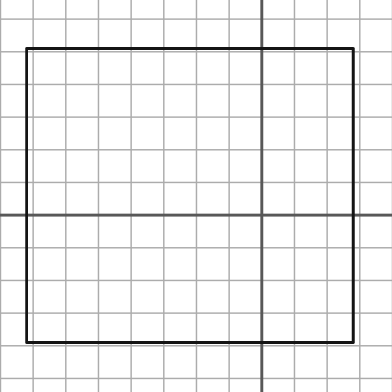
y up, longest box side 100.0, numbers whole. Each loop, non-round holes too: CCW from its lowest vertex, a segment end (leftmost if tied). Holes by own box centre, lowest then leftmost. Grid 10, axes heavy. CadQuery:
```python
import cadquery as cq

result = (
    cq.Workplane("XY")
    .moveTo(-72.0, -39.0)
    .lineTo(28.0, -39.0)
    .lineTo(28.0, 51.0)
    .lineTo(-72.0, 51.0)
    .close()
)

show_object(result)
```